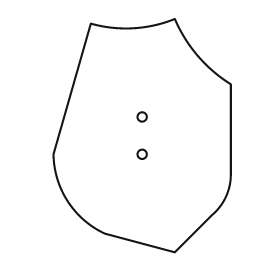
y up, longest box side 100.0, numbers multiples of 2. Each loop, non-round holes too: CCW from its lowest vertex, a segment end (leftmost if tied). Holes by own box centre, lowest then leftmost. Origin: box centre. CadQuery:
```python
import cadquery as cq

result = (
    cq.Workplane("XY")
    .moveTo(14.0, -50.0)
    .lineTo(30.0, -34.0)
    .threePointArc((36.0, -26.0), (38.0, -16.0))
    .lineTo(38.0, 22.0)
    .threePointArc((24.0, 34.0), (14.0, 50.0))
    .threePointArc((-4.0, 46.0), (-22.0, 48.0))
    .lineTo(-38.0, -8.0)
    .threePointArc((-32.0, -28.0), (-16.0, -42.0))
    .close()
    .moveTo(0.0, -8.0)
    .circle(2.0)
    .moveTo(0.0, 8.0)
    .circle(2.0)
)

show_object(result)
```